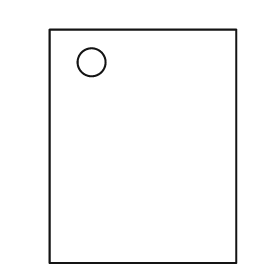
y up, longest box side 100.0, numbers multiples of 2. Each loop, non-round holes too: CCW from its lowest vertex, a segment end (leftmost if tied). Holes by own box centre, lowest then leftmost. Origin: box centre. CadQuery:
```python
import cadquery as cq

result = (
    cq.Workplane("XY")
    .moveTo(-40.0, -50.0)
    .lineTo(40.0, -50.0)
    .lineTo(40.0, 50.0)
    .lineTo(-40.0, 50.0)
    .close()
    .moveTo(-22.0, 36.0)
    .circle(6.0)
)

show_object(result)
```